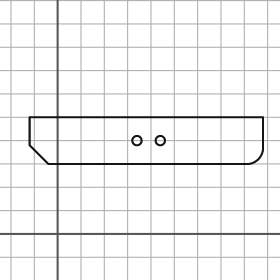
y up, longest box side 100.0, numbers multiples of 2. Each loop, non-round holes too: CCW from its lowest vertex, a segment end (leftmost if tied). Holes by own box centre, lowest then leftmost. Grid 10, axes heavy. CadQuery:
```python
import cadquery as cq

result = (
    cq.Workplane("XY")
    .moveTo(-4.0, 30.0)
    .lineTo(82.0, 30.0)
    .threePointArc((86.0, 32.0), (88.0, 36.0))
    .lineTo(88.0, 50.0)
    .lineTo(-12.0, 50.0)
    .lineTo(-12.0, 38.0)
    .close()
    .moveTo(34.0, 40.0)
    .circle(2.0)
    .moveTo(44.0, 40.0)
    .circle(2.0)
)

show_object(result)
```